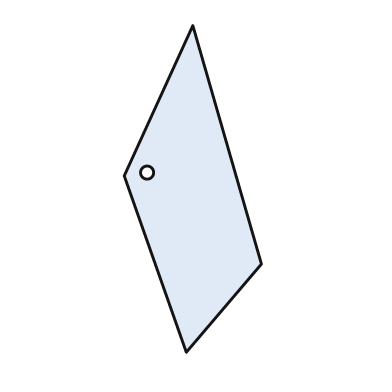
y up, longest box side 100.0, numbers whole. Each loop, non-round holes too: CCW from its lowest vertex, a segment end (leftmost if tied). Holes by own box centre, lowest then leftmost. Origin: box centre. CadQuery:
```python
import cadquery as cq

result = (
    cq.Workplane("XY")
    .moveTo(-2.0, -50.0)
    .lineTo(21.0, -23.0)
    .lineTo(0.0, 50.0)
    .lineTo(-21.0, 4.0)
    .close()
    .moveTo(-14.0, 5.0)
    .circle(2.0)
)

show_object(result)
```